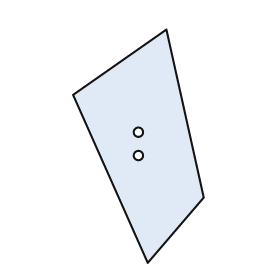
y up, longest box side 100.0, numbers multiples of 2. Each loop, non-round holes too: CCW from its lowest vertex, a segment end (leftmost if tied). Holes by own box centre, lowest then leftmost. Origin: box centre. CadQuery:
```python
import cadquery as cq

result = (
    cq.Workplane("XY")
    .moveTo(4.0, -50.0)
    .lineTo(28.0, -22.0)
    .lineTo(12.0, 50.0)
    .lineTo(-28.0, 22.0)
    .close()
    .moveTo(0.0, -4.0)
    .circle(2.0)
    .moveTo(0.0, 6.0)
    .circle(2.0)
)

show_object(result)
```